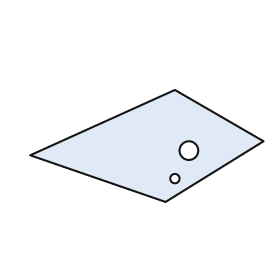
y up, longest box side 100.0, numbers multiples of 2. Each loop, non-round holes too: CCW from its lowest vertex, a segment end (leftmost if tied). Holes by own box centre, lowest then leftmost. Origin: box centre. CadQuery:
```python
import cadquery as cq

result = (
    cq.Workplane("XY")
    .moveTo(8.0, -24.0)
    .lineTo(50.0, 2.0)
    .lineTo(12.0, 24.0)
    .lineTo(-50.0, -4.0)
    .close()
    .moveTo(12.0, -14.0)
    .circle(2.0)
    .moveTo(18.0, -2.0)
    .circle(4.0)
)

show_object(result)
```